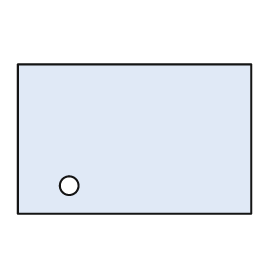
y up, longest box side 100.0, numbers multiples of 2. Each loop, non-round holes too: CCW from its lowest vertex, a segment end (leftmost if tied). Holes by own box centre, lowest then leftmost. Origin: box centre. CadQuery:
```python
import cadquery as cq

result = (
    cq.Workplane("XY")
    .moveTo(-50.0, -32.0)
    .lineTo(50.0, -32.0)
    .lineTo(50.0, 32.0)
    .lineTo(-50.0, 32.0)
    .close()
    .moveTo(-28.0, -20.0)
    .circle(4.0)
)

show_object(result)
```